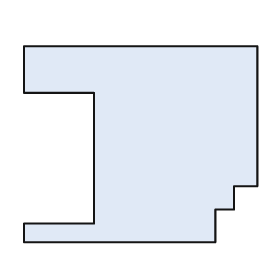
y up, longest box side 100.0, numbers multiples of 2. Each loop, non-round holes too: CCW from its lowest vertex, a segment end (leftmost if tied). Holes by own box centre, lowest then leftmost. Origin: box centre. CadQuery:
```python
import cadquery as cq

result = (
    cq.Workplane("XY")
    .moveTo(-50.0, -42.0)
    .lineTo(32.0, -42.0)
    .lineTo(32.0, -28.0)
    .lineTo(40.0, -28.0)
    .lineTo(40.0, -18.0)
    .lineTo(50.0, -18.0)
    .lineTo(50.0, 42.0)
    .lineTo(-50.0, 42.0)
    .lineTo(-50.0, 22.0)
    .lineTo(-20.0, 22.0)
    .lineTo(-20.0, -34.0)
    .lineTo(-50.0, -34.0)
    .close()
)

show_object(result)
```